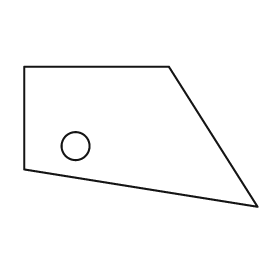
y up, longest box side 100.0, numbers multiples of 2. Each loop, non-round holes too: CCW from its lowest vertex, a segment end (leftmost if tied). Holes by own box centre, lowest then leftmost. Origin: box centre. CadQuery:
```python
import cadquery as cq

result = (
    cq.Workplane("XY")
    .moveTo(50.0, -30.0)
    .lineTo(12.0, 30.0)
    .lineTo(-50.0, 30.0)
    .lineTo(-50.0, -14.0)
    .close()
    .moveTo(-28.0, -4.0)
    .circle(6.0)
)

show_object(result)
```